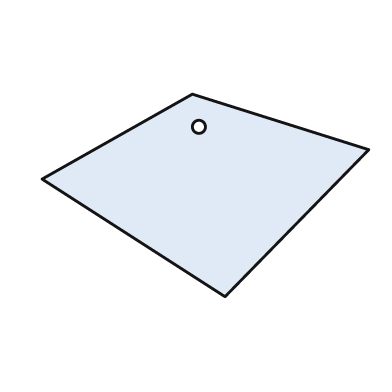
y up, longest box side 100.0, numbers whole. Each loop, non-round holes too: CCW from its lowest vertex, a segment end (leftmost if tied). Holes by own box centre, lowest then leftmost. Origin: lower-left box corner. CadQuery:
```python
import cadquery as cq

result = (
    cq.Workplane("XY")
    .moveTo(56.0, 0.0)
    .lineTo(100.0, 45.0)
    .lineTo(46.0, 62.0)
    .lineTo(0.0, 36.0)
    .close()
    .moveTo(48.0, 52.0)
    .circle(2.0)
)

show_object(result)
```